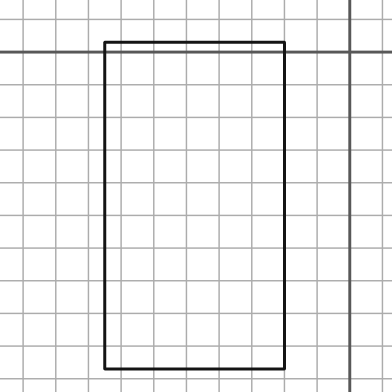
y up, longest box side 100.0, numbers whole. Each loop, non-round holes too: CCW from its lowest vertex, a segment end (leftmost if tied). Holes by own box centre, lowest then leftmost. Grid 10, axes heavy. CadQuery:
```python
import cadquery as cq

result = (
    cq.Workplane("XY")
    .moveTo(-75.0, -97.0)
    .lineTo(-20.0, -97.0)
    .lineTo(-20.0, 3.0)
    .lineTo(-75.0, 3.0)
    .close()
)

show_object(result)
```